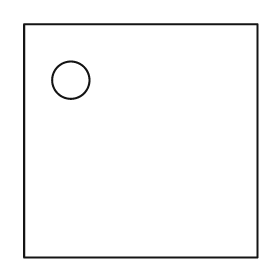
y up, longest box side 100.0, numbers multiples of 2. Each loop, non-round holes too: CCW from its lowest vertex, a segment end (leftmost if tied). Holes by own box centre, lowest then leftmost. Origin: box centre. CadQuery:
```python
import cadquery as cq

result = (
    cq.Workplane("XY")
    .moveTo(-50.0, -50.0)
    .lineTo(50.0, -50.0)
    .lineTo(50.0, 50.0)
    .lineTo(-50.0, 50.0)
    .close()
    .moveTo(-30.0, 26.0)
    .circle(8.0)
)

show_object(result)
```